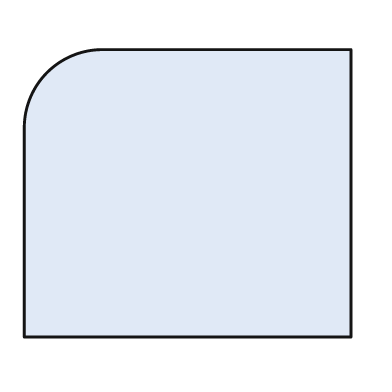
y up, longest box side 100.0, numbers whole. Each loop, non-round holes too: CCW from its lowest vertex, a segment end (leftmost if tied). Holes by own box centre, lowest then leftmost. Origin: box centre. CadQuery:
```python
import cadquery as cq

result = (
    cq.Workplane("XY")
    .moveTo(-50.0, -44.0)
    .lineTo(50.0, -44.0)
    .lineTo(50.0, 44.0)
    .lineTo(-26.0, 44.0)
    .threePointArc((-43.0, 37.0), (-50.0, 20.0))
    .close()
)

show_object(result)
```